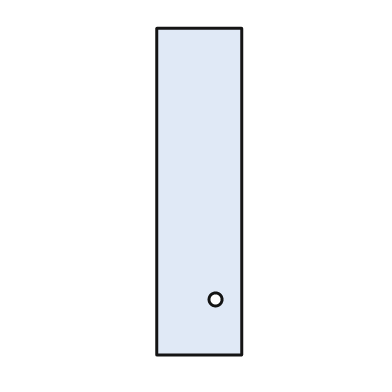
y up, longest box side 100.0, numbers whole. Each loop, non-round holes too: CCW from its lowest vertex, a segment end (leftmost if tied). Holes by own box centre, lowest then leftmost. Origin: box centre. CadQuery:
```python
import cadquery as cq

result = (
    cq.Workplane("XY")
    .moveTo(-13.0, -50.0)
    .lineTo(13.0, -50.0)
    .lineTo(13.0, 50.0)
    .lineTo(-13.0, 50.0)
    .close()
    .moveTo(5.0, -33.0)
    .circle(2.0)
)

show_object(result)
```